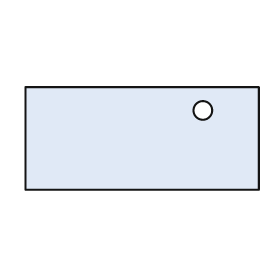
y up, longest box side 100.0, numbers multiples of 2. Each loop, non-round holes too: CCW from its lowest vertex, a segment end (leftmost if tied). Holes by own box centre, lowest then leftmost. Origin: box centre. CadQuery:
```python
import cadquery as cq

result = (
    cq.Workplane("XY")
    .moveTo(-50.0, -22.0)
    .lineTo(50.0, -22.0)
    .lineTo(50.0, 22.0)
    .lineTo(-50.0, 22.0)
    .close()
    .moveTo(26.0, 12.0)
    .circle(4.0)
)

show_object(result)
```